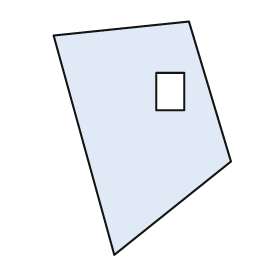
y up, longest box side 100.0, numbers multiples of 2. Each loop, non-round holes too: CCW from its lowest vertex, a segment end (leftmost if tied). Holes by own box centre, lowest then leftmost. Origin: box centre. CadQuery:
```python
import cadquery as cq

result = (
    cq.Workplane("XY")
    .moveTo(-12.0, -50.0)
    .lineTo(38.0, -10.0)
    .lineTo(20.0, 50.0)
    .lineTo(-38.0, 44.0)
    .close()
    .moveTo(6.0, 12.0)
    .lineTo(18.0, 12.0)
    .lineTo(18.0, 28.0)
    .lineTo(6.0, 28.0)
    .close()
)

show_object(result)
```